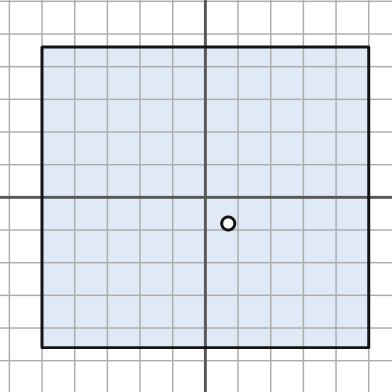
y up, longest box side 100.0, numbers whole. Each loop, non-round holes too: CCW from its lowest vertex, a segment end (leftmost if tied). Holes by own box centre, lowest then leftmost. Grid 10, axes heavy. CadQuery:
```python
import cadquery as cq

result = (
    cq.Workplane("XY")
    .moveTo(-50.0, -46.0)
    .lineTo(50.0, -46.0)
    .lineTo(50.0, 46.0)
    .lineTo(-50.0, 46.0)
    .close()
    .moveTo(7.0, -8.0)
    .circle(2.0)
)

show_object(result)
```